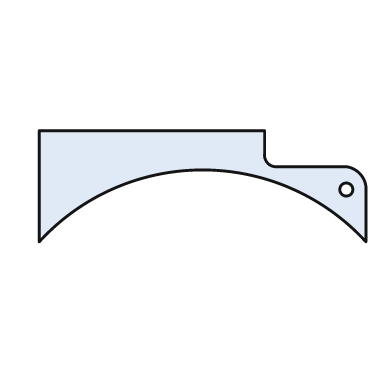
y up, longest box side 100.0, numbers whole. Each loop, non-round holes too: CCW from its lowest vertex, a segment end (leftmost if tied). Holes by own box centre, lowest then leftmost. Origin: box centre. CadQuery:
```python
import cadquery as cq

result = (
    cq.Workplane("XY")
    .moveTo(-50.0, -17.0)
    .threePointArc((0.0, 5.0), (50.0, -17.0))
    .lineTo(50.0, 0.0)
    .threePointArc((48.0, 4.0), (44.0, 6.0))
    .lineTo(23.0, 6.0)
    .threePointArc((20.0, 7.0), (19.0, 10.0))
    .lineTo(19.0, 17.0)
    .lineTo(-50.0, 17.0)
    .close()
    .moveTo(44.0, -1.0)
    .circle(2.0)
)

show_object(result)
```